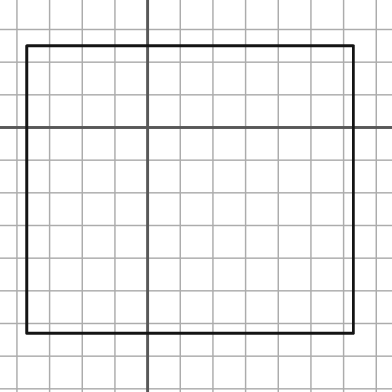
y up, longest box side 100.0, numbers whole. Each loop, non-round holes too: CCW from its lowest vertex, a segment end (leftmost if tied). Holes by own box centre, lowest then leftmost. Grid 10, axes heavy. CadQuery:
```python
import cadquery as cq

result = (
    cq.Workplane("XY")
    .moveTo(-37.0, -63.0)
    .lineTo(63.0, -63.0)
    .lineTo(63.0, 25.0)
    .lineTo(-37.0, 25.0)
    .close()
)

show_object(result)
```